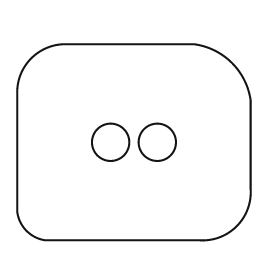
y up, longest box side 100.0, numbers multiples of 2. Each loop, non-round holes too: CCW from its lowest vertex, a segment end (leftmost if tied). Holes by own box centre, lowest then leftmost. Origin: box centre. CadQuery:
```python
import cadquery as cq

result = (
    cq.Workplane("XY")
    .moveTo(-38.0, -42.0)
    .lineTo(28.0, -42.0)
    .threePointArc((44.0, -36.0), (50.0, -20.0))
    .lineTo(50.0, 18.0)
    .threePointArc((42.0, 34.0), (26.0, 42.0))
    .lineTo(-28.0, 42.0)
    .threePointArc((-44.0, 36.0), (-50.0, 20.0))
    .lineTo(-50.0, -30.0)
    .threePointArc((-46.0, -38.0), (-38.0, -42.0))
    .close()
    .moveTo(-10.0, 0.0)
    .circle(8.0)
    .moveTo(10.0, 0.0)
    .circle(8.0)
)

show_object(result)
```